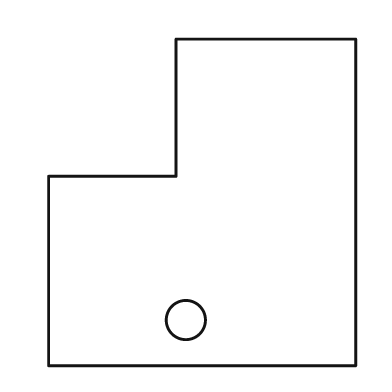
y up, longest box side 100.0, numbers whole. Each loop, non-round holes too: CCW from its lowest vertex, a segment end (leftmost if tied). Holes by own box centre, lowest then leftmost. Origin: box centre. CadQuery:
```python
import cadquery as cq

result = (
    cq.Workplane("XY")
    .moveTo(-47.0, -50.0)
    .lineTo(47.0, -50.0)
    .lineTo(47.0, 50.0)
    .lineTo(-8.0, 50.0)
    .lineTo(-8.0, 8.0)
    .lineTo(-47.0, 8.0)
    .close()
    .moveTo(-5.0, -36.0)
    .circle(6.0)
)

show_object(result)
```